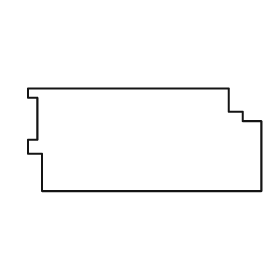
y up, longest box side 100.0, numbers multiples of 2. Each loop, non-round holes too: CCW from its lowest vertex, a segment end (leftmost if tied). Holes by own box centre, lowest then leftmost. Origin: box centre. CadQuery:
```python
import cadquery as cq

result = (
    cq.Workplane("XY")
    .moveTo(-44.0, -22.0)
    .lineTo(50.0, -22.0)
    .lineTo(50.0, 8.0)
    .lineTo(42.0, 8.0)
    .lineTo(42.0, 12.0)
    .lineTo(36.0, 12.0)
    .lineTo(36.0, 22.0)
    .lineTo(-50.0, 22.0)
    .lineTo(-50.0, 18.0)
    .lineTo(-46.0, 18.0)
    .lineTo(-46.0, 0.0)
    .lineTo(-50.0, 0.0)
    .lineTo(-50.0, -6.0)
    .lineTo(-44.0, -6.0)
    .close()
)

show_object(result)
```